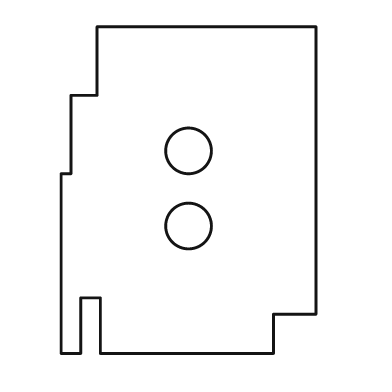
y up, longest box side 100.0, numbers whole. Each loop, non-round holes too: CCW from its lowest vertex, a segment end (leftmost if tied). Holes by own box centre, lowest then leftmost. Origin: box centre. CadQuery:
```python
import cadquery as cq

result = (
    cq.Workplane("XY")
    .moveTo(-39.0, -50.0)
    .lineTo(-33.0, -50.0)
    .lineTo(-33.0, -33.0)
    .lineTo(-27.0, -33.0)
    .lineTo(-27.0, -50.0)
    .lineTo(26.0, -50.0)
    .lineTo(26.0, -38.0)
    .lineTo(39.0, -38.0)
    .lineTo(39.0, 50.0)
    .lineTo(-28.0, 50.0)
    .lineTo(-28.0, 29.0)
    .lineTo(-36.0, 29.0)
    .lineTo(-36.0, 5.0)
    .lineTo(-39.0, 5.0)
    .close()
    .moveTo(0.0, -11.0)
    .circle(7.0)
    .moveTo(0.0, 12.0)
    .circle(7.0)
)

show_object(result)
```